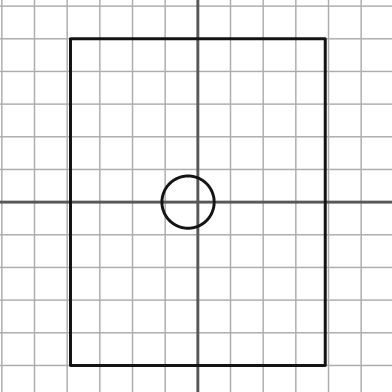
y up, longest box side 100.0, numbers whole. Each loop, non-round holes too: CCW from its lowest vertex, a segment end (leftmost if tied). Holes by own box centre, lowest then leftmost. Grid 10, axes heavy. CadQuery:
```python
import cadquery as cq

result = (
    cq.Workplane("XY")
    .moveTo(-39.0, -50.0)
    .lineTo(39.0, -50.0)
    .lineTo(39.0, 50.0)
    .lineTo(-39.0, 50.0)
    .close()
    .moveTo(-3.0, 0.0)
    .circle(8.0)
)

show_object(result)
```